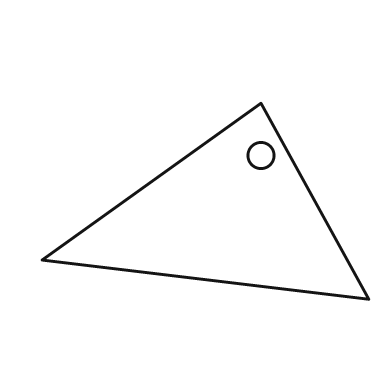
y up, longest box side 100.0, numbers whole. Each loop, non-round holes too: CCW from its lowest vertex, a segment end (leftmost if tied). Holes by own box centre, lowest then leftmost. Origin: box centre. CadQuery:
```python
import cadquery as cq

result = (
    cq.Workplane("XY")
    .moveTo(50.0, -30.0)
    .lineTo(17.0, 30.0)
    .lineTo(-50.0, -18.0)
    .close()
    .moveTo(17.0, 14.0)
    .circle(4.0)
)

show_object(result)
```